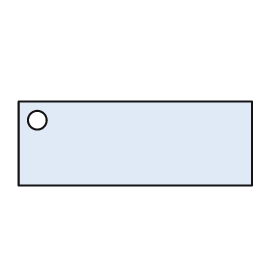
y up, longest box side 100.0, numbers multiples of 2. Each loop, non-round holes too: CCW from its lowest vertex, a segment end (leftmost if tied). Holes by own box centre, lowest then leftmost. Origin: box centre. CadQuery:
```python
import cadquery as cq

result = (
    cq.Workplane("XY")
    .moveTo(-50.0, -18.0)
    .lineTo(50.0, -18.0)
    .lineTo(50.0, 18.0)
    .lineTo(-50.0, 18.0)
    .close()
    .moveTo(-42.0, 10.0)
    .circle(4.0)
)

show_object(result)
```